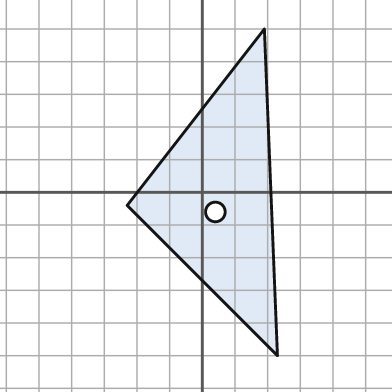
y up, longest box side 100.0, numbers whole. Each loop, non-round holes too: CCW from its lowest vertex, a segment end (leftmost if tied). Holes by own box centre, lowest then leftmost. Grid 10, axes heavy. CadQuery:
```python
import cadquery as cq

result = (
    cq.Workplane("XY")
    .moveTo(23.0, -50.0)
    .lineTo(19.0, 50.0)
    .lineTo(-23.0, -4.0)
    .close()
    .moveTo(4.0, -6.0)
    .circle(3.0)
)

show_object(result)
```